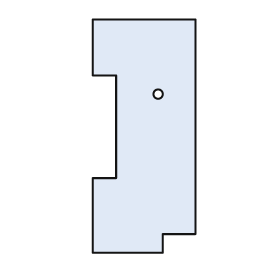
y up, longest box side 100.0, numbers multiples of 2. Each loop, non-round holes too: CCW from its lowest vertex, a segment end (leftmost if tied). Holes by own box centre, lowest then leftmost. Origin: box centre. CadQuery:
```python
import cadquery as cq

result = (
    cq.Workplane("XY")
    .moveTo(-22.0, -50.0)
    .lineTo(8.0, -50.0)
    .lineTo(8.0, -42.0)
    .lineTo(22.0, -42.0)
    .lineTo(22.0, 50.0)
    .lineTo(-22.0, 50.0)
    .lineTo(-22.0, 26.0)
    .lineTo(-12.0, 26.0)
    .lineTo(-12.0, -18.0)
    .lineTo(-22.0, -18.0)
    .close()
    .moveTo(6.0, 18.0)
    .circle(2.0)
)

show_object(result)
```